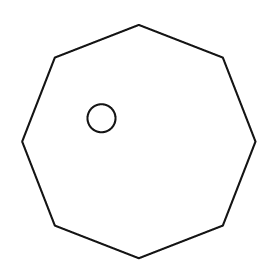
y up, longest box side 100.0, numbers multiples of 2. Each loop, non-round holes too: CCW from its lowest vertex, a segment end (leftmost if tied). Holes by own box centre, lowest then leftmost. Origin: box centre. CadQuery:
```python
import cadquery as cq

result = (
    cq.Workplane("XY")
    .moveTo(0.0, -50.0)
    .lineTo(36.0, -36.0)
    .lineTo(50.0, 0.0)
    .lineTo(36.0, 36.0)
    .lineTo(0.0, 50.0)
    .lineTo(-36.0, 36.0)
    .lineTo(-50.0, 0.0)
    .lineTo(-36.0, -36.0)
    .close()
    .moveTo(-16.0, 10.0)
    .circle(6.0)
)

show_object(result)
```